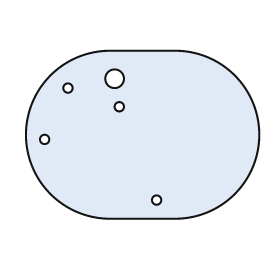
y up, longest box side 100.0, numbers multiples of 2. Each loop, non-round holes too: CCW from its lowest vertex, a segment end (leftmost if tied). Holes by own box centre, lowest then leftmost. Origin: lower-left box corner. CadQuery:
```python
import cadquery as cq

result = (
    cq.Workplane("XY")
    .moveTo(36.0, 0.0)
    .lineTo(64.0, 0.0)
    .threePointArc((100.0, 36.0), (64.0, 72.0))
    .lineTo(36.0, 72.0)
    .threePointArc((0.0, 36.0), (36.0, 0.0))
    .close()
    .moveTo(56.0, 8.0)
    .circle(2.0)
    .moveTo(8.0, 34.0)
    .circle(2.0)
    .moveTo(40.0, 48.0)
    .circle(2.0)
    .moveTo(18.0, 56.0)
    .circle(2.0)
    .moveTo(38.0, 60.0)
    .circle(4.0)
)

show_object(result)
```